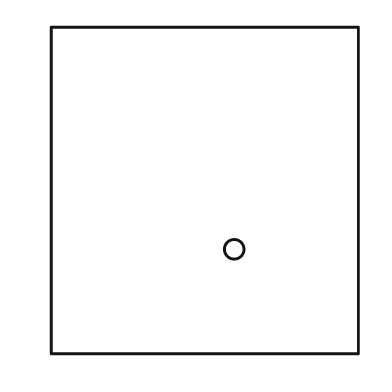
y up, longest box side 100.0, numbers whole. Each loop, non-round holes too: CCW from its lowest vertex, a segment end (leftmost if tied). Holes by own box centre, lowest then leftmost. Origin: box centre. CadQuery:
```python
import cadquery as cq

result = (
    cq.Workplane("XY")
    .moveTo(-47.0, -50.0)
    .lineTo(47.0, -50.0)
    .lineTo(47.0, 50.0)
    .lineTo(-47.0, 50.0)
    .close()
    .moveTo(9.0, -18.0)
    .circle(3.0)
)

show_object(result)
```